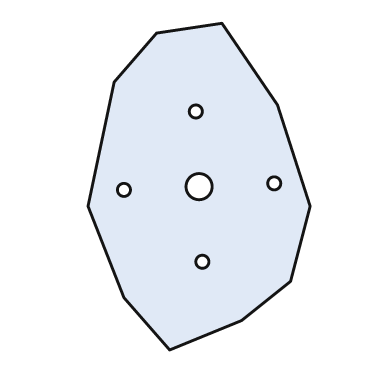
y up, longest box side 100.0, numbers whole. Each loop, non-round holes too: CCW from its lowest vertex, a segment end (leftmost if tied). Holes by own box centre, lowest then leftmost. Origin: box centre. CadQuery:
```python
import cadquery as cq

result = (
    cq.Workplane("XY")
    .moveTo(-9.0, -50.0)
    .lineTo(13.0, -41.0)
    .lineTo(28.0, -29.0)
    .lineTo(34.0, -6.0)
    .lineTo(24.0, 25.0)
    .lineTo(7.0, 50.0)
    .lineTo(-13.0, 47.0)
    .lineTo(-26.0, 32.0)
    .lineTo(-34.0, -6.0)
    .lineTo(-23.0, -34.0)
    .close()
    .moveTo(1.0, -23.0)
    .circle(2.0)
    .moveTo(-23.0, -1.0)
    .circle(2.0)
    .moveTo(0.0, 0.0)
    .circle(4.0)
    .moveTo(23.0, 1.0)
    .circle(2.0)
    .moveTo(-1.0, 23.0)
    .circle(2.0)
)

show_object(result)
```